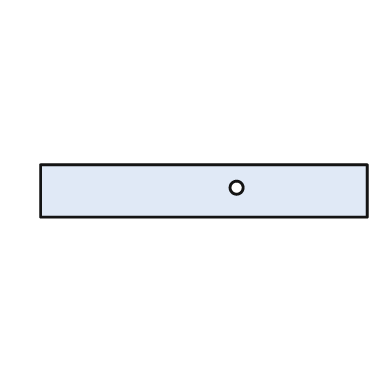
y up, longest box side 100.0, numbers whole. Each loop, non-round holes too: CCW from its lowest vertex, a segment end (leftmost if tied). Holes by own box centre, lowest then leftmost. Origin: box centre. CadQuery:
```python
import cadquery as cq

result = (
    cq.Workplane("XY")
    .moveTo(-50.0, -8.0)
    .lineTo(50.0, -8.0)
    .lineTo(50.0, 8.0)
    .lineTo(-50.0, 8.0)
    .close()
    .moveTo(10.0, 1.0)
    .circle(2.0)
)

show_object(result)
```